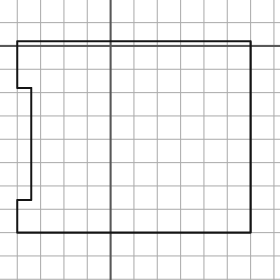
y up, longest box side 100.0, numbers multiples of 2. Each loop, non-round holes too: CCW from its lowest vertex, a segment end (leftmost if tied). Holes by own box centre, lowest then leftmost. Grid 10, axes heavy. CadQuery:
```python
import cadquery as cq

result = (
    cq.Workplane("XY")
    .moveTo(-40.0, -80.0)
    .lineTo(60.0, -80.0)
    .lineTo(60.0, 2.0)
    .lineTo(-40.0, 2.0)
    .lineTo(-40.0, -18.0)
    .lineTo(-34.0, -18.0)
    .lineTo(-34.0, -66.0)
    .lineTo(-40.0, -66.0)
    .close()
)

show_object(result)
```